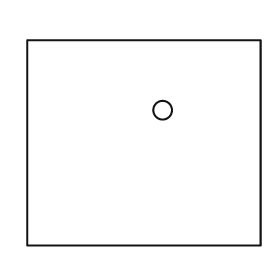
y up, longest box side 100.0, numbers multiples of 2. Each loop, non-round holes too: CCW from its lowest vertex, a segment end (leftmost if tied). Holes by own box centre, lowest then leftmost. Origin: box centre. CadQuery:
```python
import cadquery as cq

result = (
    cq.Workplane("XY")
    .moveTo(-50.0, -44.0)
    .lineTo(50.0, -44.0)
    .lineTo(50.0, 44.0)
    .lineTo(-50.0, 44.0)
    .close()
    .moveTo(8.0, 14.0)
    .circle(4.0)
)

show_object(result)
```